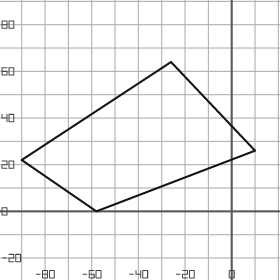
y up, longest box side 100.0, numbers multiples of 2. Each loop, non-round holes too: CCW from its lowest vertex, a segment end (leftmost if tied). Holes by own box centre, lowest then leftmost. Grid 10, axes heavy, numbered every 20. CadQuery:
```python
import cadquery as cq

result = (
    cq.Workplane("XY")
    .moveTo(-58.0, 0.0)
    .lineTo(10.0, 26.0)
    .lineTo(-26.0, 64.0)
    .lineTo(-90.0, 22.0)
    .close()
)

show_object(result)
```